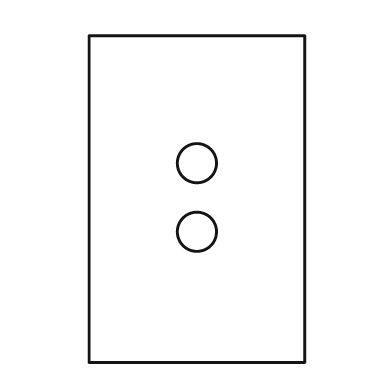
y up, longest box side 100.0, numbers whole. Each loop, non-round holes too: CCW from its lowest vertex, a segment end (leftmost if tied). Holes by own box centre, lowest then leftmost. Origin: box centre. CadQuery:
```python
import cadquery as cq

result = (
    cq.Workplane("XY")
    .moveTo(-33.0, -50.0)
    .lineTo(33.0, -50.0)
    .lineTo(33.0, 50.0)
    .lineTo(-33.0, 50.0)
    .close()
    .moveTo(0.0, -10.0)
    .circle(6.0)
    .moveTo(0.0, 11.0)
    .circle(6.0)
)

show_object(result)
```